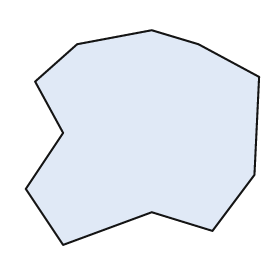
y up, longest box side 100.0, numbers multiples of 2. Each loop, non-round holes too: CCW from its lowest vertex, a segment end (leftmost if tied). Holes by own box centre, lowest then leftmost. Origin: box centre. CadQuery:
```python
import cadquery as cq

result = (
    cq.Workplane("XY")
    .moveTo(-34.0, -46.0)
    .lineTo(4.0, -32.0)
    .lineTo(30.0, -40.0)
    .lineTo(48.0, -16.0)
    .lineTo(50.0, 26.0)
    .lineTo(24.0, 40.0)
    .lineTo(4.0, 46.0)
    .lineTo(-28.0, 40.0)
    .lineTo(-46.0, 24.0)
    .lineTo(-34.0, 2.0)
    .lineTo(-50.0, -22.0)
    .close()
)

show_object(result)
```